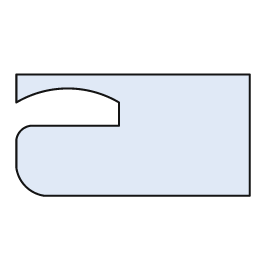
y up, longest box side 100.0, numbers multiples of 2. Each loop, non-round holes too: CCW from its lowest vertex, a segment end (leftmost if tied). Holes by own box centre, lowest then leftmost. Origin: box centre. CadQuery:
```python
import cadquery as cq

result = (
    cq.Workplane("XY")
    .moveTo(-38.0, -26.0)
    .lineTo(50.0, -26.0)
    .lineTo(50.0, 26.0)
    .lineTo(-50.0, 26.0)
    .lineTo(-50.0, 14.0)
    .threePointArc((-28.0, 20.0), (-6.0, 14.0))
    .lineTo(-6.0, 4.0)
    .lineTo(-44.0, 4.0)
    .threePointArc((-48.0, 2.0), (-50.0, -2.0))
    .lineTo(-50.0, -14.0)
    .threePointArc((-46.0, -22.0), (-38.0, -26.0))
    .close()
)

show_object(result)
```